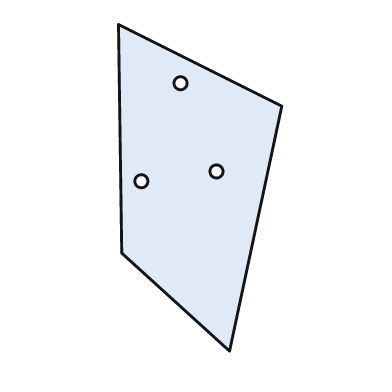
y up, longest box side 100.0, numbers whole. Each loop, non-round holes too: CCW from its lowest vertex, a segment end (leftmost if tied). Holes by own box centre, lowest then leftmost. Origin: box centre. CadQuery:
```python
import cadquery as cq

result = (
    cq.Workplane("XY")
    .moveTo(9.0, -50.0)
    .lineTo(25.0, 25.0)
    .lineTo(-25.0, 50.0)
    .lineTo(-24.0, -20.0)
    .close()
    .moveTo(-18.0, 2.0)
    .circle(2.0)
    .moveTo(5.0, 5.0)
    .circle(2.0)
    .moveTo(-6.0, 32.0)
    .circle(2.0)
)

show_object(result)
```